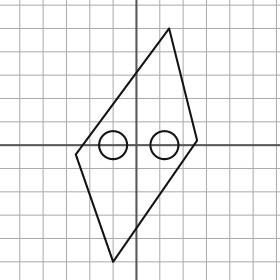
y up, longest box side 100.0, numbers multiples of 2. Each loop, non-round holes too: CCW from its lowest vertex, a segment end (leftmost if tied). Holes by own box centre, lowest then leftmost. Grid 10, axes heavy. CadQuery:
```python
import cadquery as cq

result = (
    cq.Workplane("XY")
    .moveTo(-10.0, -50.0)
    .lineTo(26.0, 2.0)
    .lineTo(14.0, 50.0)
    .lineTo(-26.0, -4.0)
    .close()
    .moveTo(-10.0, 0.0)
    .circle(6.0)
    .moveTo(12.0, 0.0)
    .circle(6.0)
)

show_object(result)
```